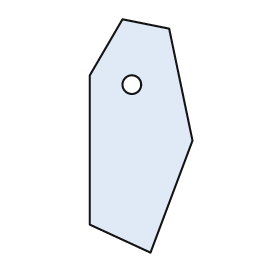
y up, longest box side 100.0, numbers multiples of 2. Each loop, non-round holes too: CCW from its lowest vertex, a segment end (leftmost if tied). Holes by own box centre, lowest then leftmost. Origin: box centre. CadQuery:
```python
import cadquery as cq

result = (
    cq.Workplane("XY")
    .moveTo(4.0, -50.0)
    .lineTo(22.0, -2.0)
    .lineTo(12.0, 46.0)
    .lineTo(-8.0, 50.0)
    .lineTo(-22.0, 26.0)
    .lineTo(-22.0, -38.0)
    .close()
    .moveTo(-4.0, 22.0)
    .circle(4.0)
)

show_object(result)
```